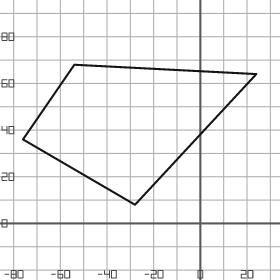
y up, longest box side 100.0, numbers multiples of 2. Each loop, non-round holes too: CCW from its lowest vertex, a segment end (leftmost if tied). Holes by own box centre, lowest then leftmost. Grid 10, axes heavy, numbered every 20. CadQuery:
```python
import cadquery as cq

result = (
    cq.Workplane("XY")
    .moveTo(-28.0, 8.0)
    .lineTo(24.0, 64.0)
    .lineTo(-54.0, 68.0)
    .lineTo(-76.0, 36.0)
    .close()
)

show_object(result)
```